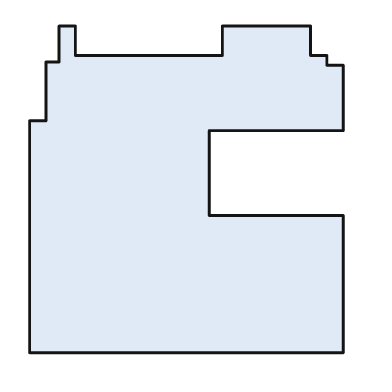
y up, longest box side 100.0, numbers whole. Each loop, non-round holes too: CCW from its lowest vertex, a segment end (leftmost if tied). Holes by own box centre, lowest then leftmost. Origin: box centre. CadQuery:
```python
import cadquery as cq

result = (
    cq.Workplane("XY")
    .moveTo(-48.0, -50.0)
    .lineTo(48.0, -50.0)
    .lineTo(48.0, -8.0)
    .lineTo(7.0, -8.0)
    .lineTo(7.0, 18.0)
    .lineTo(48.0, 18.0)
    .lineTo(48.0, 38.0)
    .lineTo(43.0, 38.0)
    .lineTo(43.0, 41.0)
    .lineTo(38.0, 41.0)
    .lineTo(38.0, 50.0)
    .lineTo(11.0, 50.0)
    .lineTo(11.0, 41.0)
    .lineTo(-34.0, 41.0)
    .lineTo(-34.0, 50.0)
    .lineTo(-39.0, 50.0)
    .lineTo(-39.0, 39.0)
    .lineTo(-43.0, 39.0)
    .lineTo(-43.0, 21.0)
    .lineTo(-48.0, 21.0)
    .close()
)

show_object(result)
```